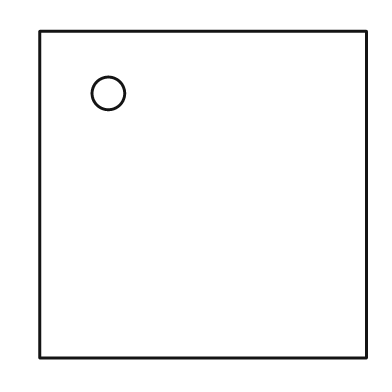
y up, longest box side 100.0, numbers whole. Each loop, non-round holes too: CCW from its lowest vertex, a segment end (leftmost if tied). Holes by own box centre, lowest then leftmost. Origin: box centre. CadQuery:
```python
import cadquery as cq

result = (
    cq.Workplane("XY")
    .moveTo(-50.0, -50.0)
    .lineTo(50.0, -50.0)
    .lineTo(50.0, 50.0)
    .lineTo(-50.0, 50.0)
    .close()
    .moveTo(-29.0, 31.0)
    .circle(5.0)
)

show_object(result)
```